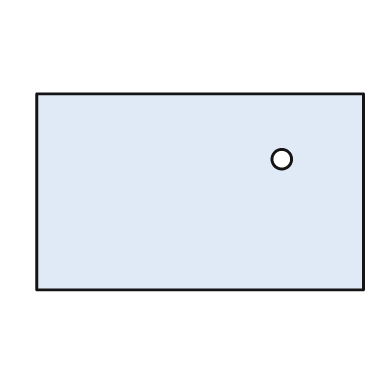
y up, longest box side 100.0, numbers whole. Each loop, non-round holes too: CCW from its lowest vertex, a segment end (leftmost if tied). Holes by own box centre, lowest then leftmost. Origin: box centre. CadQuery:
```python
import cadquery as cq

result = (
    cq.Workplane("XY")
    .moveTo(-50.0, -30.0)
    .lineTo(50.0, -30.0)
    .lineTo(50.0, 30.0)
    .lineTo(-50.0, 30.0)
    .close()
    .moveTo(25.0, 10.0)
    .circle(3.0)
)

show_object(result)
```